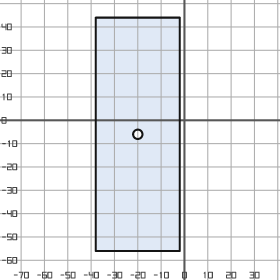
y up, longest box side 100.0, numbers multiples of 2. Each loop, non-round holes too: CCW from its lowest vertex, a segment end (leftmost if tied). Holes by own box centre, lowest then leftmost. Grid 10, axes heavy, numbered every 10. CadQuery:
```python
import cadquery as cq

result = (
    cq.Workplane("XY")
    .moveTo(-38.0, -56.0)
    .lineTo(-2.0, -56.0)
    .lineTo(-2.0, 44.0)
    .lineTo(-38.0, 44.0)
    .close()
    .moveTo(-20.0, -6.0)
    .circle(2.0)
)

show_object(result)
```